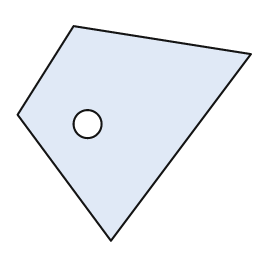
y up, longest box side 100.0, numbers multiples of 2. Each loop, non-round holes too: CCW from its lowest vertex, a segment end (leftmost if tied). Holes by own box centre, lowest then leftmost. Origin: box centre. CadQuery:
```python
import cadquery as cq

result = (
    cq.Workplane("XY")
    .moveTo(-10.0, -46.0)
    .lineTo(50.0, 34.0)
    .lineTo(-26.0, 46.0)
    .lineTo(-50.0, 8.0)
    .close()
    .moveTo(-20.0, 4.0)
    .circle(6.0)
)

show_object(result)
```